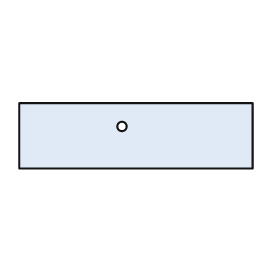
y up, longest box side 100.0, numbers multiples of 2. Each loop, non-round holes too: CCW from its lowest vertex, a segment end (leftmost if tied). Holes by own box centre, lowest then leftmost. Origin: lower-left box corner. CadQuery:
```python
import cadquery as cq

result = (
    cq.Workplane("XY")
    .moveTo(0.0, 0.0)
    .lineTo(100.0, 0.0)
    .lineTo(100.0, 28.0)
    .lineTo(0.0, 28.0)
    .close()
    .moveTo(44.0, 18.0)
    .circle(2.0)
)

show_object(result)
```